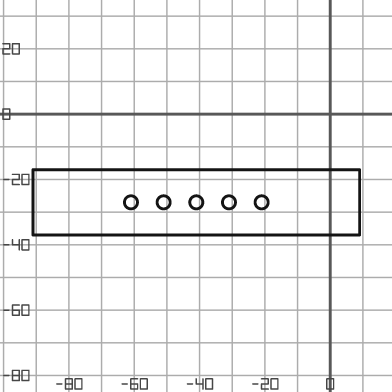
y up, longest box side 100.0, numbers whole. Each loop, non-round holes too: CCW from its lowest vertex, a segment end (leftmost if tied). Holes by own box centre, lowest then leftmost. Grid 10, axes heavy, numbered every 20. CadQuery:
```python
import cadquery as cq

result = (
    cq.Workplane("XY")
    .moveTo(-91.0, -37.0)
    .lineTo(9.0, -37.0)
    .lineTo(9.0, -17.0)
    .lineTo(-91.0, -17.0)
    .close()
    .moveTo(-61.0, -27.0)
    .circle(2.0)
    .moveTo(-51.0, -27.0)
    .circle(2.0)
    .moveTo(-41.0, -27.0)
    .circle(2.0)
    .moveTo(-31.0, -27.0)
    .circle(2.0)
    .moveTo(-21.0, -27.0)
    .circle(2.0)
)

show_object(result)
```